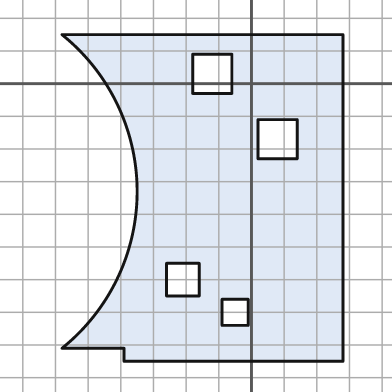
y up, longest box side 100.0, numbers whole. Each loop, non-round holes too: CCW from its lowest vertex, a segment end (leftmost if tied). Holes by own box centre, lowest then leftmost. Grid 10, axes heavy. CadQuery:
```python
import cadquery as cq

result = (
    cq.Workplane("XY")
    .moveTo(-39.0, -85.0)
    .lineTo(28.0, -85.0)
    .lineTo(28.0, 15.0)
    .lineTo(-58.0, 15.0)
    .threePointArc((-35.0, -33.0), (-58.0, -81.0))
    .lineTo(-39.0, -81.0)
    .close()
    .moveTo(-9.0, -74.0)
    .lineTo(-1.0, -74.0)
    .lineTo(-1.0, -66.0)
    .lineTo(-9.0, -66.0)
    .close()
    .moveTo(-26.0, -65.0)
    .lineTo(-16.0, -65.0)
    .lineTo(-16.0, -55.0)
    .lineTo(-26.0, -55.0)
    .close()
    .moveTo(2.0, -23.0)
    .lineTo(14.0, -23.0)
    .lineTo(14.0, -11.0)
    .lineTo(2.0, -11.0)
    .close()
    .moveTo(-18.0, -3.0)
    .lineTo(-6.0, -3.0)
    .lineTo(-6.0, 9.0)
    .lineTo(-18.0, 9.0)
    .close()
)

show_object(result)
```